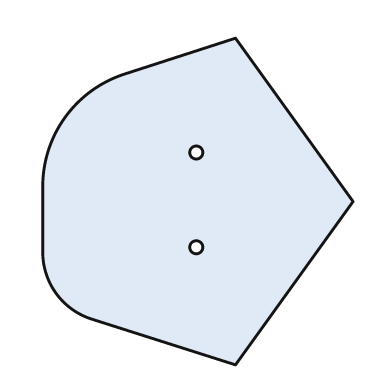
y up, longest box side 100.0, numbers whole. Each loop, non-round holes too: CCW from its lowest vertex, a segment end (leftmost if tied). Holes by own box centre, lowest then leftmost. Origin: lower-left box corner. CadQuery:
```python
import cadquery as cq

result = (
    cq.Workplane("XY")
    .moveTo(59.0, 0.0)
    .lineTo(95.0, 50.0)
    .lineTo(59.0, 100.0)
    .lineTo(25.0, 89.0)
    .threePointArc((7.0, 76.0), (0.0, 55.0))
    .lineTo(0.0, 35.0)
    .threePointArc((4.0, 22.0), (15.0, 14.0))
    .close()
    .moveTo(47.0, 36.0)
    .circle(2.0)
    .moveTo(47.0, 65.0)
    .circle(2.0)
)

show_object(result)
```